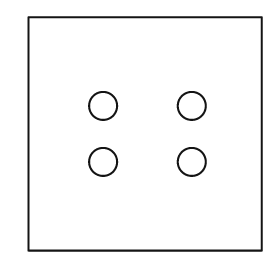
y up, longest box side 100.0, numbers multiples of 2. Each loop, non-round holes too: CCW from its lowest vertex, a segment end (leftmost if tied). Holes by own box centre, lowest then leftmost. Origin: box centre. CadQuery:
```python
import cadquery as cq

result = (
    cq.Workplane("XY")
    .moveTo(-50.0, -50.0)
    .lineTo(50.0, -50.0)
    .lineTo(50.0, 50.0)
    .lineTo(-50.0, 50.0)
    .close()
    .moveTo(-18.0, -12.0)
    .circle(6.0)
    .moveTo(20.0, -12.0)
    .circle(6.0)
    .moveTo(-18.0, 12.0)
    .circle(6.0)
    .moveTo(20.0, 12.0)
    .circle(6.0)
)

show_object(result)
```